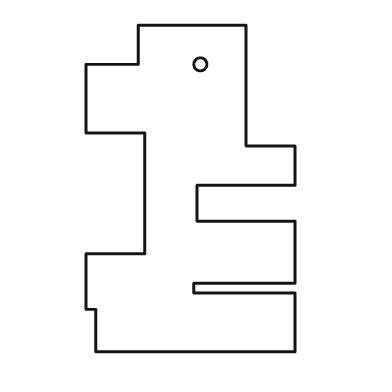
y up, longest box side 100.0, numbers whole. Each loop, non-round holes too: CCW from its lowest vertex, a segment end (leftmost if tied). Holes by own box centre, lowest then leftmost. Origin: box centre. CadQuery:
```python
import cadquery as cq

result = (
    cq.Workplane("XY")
    .moveTo(-29.0, -50.0)
    .lineTo(32.0, -50.0)
    .lineTo(32.0, -32.0)
    .lineTo(1.0, -32.0)
    .lineTo(1.0, -29.0)
    .lineTo(32.0, -29.0)
    .lineTo(32.0, -10.0)
    .lineTo(2.0, -10.0)
    .lineTo(2.0, 1.0)
    .lineTo(32.0, 1.0)
    .lineTo(32.0, 13.0)
    .lineTo(17.0, 13.0)
    .lineTo(17.0, 50.0)
    .lineTo(-16.0, 50.0)
    .lineTo(-16.0, 38.0)
    .lineTo(-32.0, 38.0)
    .lineTo(-32.0, 17.0)
    .lineTo(-14.0, 17.0)
    .lineTo(-14.0, -20.0)
    .lineTo(-32.0, -20.0)
    .lineTo(-32.0, -37.0)
    .lineTo(-29.0, -37.0)
    .close()
    .moveTo(3.0, 38.0)
    .circle(2.0)
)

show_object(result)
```